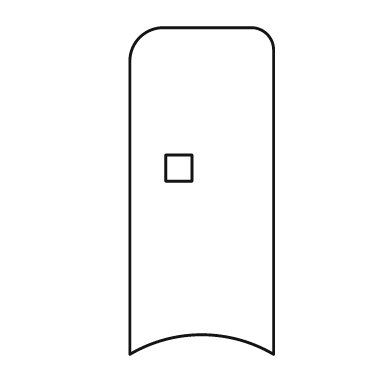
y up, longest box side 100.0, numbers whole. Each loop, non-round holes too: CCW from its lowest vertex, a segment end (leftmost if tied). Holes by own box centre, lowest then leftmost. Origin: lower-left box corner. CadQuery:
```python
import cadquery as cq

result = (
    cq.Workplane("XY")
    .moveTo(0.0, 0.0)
    .threePointArc((22.0, 6.0), (44.0, 0.0))
    .lineTo(44.0, 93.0)
    .threePointArc((42.0, 98.0), (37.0, 100.0))
    .lineTo(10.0, 100.0)
    .threePointArc((3.0, 97.0), (0.0, 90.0))
    .close()
    .moveTo(11.0, 53.0)
    .lineTo(19.0, 53.0)
    .lineTo(19.0, 61.0)
    .lineTo(11.0, 61.0)
    .close()
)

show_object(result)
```